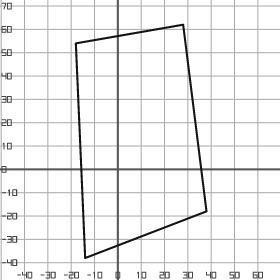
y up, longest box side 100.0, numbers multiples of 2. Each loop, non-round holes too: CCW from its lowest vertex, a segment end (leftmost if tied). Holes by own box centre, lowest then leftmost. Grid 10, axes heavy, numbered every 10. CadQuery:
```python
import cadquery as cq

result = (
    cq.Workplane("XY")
    .moveTo(-14.0, -38.0)
    .lineTo(38.0, -18.0)
    .lineTo(28.0, 62.0)
    .lineTo(-18.0, 54.0)
    .close()
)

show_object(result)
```